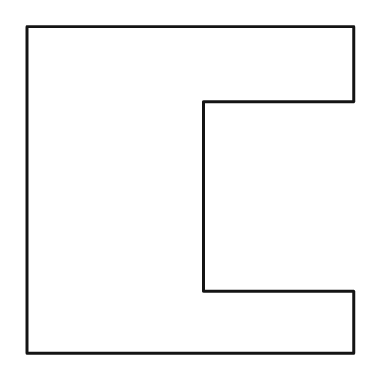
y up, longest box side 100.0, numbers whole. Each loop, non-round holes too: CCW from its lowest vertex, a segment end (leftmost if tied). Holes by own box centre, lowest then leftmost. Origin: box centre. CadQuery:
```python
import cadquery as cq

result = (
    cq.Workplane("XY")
    .moveTo(-50.0, -50.0)
    .lineTo(50.0, -50.0)
    .lineTo(50.0, -31.0)
    .lineTo(4.0, -31.0)
    .lineTo(4.0, 27.0)
    .lineTo(50.0, 27.0)
    .lineTo(50.0, 50.0)
    .lineTo(-50.0, 50.0)
    .close()
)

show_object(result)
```